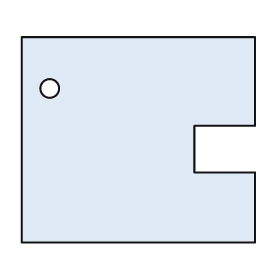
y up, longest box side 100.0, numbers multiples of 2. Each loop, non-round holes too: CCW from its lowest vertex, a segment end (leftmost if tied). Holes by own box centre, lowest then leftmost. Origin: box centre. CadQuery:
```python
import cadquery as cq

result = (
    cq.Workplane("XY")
    .moveTo(-50.0, -44.0)
    .lineTo(50.0, -44.0)
    .lineTo(50.0, -14.0)
    .lineTo(24.0, -14.0)
    .lineTo(24.0, 6.0)
    .lineTo(50.0, 6.0)
    .lineTo(50.0, 44.0)
    .lineTo(-50.0, 44.0)
    .close()
    .moveTo(-38.0, 22.0)
    .circle(4.0)
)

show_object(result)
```